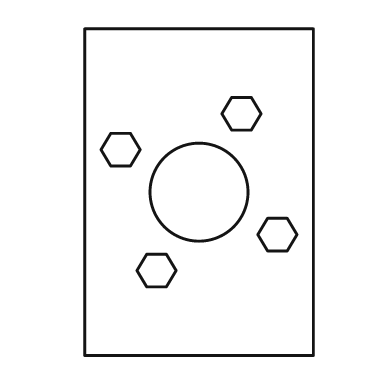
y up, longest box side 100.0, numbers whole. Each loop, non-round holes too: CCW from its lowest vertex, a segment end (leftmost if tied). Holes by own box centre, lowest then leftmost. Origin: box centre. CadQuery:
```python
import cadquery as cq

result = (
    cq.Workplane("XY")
    .moveTo(-35.0, -50.0)
    .lineTo(35.0, -50.0)
    .lineTo(35.0, 50.0)
    .lineTo(-35.0, 50.0)
    .close()
    .moveTo(-16.0, -29.0)
    .lineTo(-10.0, -29.0)
    .lineTo(-7.0, -24.0)
    .lineTo(-10.0, -19.0)
    .lineTo(-16.0, -19.0)
    .lineTo(-19.0, -24.0)
    .close()
    .moveTo(21.0, -18.0)
    .lineTo(27.0, -18.0)
    .lineTo(30.0, -13.0)
    .lineTo(27.0, -8.0)
    .lineTo(21.0, -8.0)
    .lineTo(18.0, -13.0)
    .close()
    .moveTo(0.0, 0.0)
    .circle(15.0)
    .moveTo(-27.0, 8.0)
    .lineTo(-21.0, 8.0)
    .lineTo(-18.0, 13.0)
    .lineTo(-21.0, 18.0)
    .lineTo(-27.0, 18.0)
    .lineTo(-30.0, 13.0)
    .close()
    .moveTo(10.0, 19.0)
    .lineTo(16.0, 19.0)
    .lineTo(19.0, 24.0)
    .lineTo(16.0, 29.0)
    .lineTo(10.0, 29.0)
    .lineTo(7.0, 24.0)
    .close()
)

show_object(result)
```